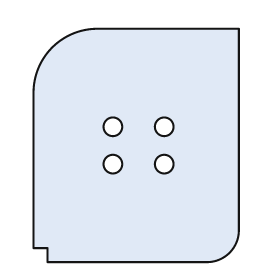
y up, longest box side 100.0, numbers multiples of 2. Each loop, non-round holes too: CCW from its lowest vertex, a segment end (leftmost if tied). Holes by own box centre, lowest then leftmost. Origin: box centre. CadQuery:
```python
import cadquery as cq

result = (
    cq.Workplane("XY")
    .moveTo(-38.0, -50.0)
    .lineTo(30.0, -50.0)
    .threePointArc((40.0, -46.0), (44.0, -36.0))
    .lineTo(44.0, 50.0)
    .lineTo(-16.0, 50.0)
    .threePointArc((-36.0, 42.0), (-44.0, 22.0))
    .lineTo(-44.0, -44.0)
    .lineTo(-38.0, -44.0)
    .close()
    .moveTo(-10.0, -8.0)
    .circle(4.0)
    .moveTo(12.0, -8.0)
    .circle(4.0)
    .moveTo(-10.0, 8.0)
    .circle(4.0)
    .moveTo(12.0, 8.0)
    .circle(4.0)
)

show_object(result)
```